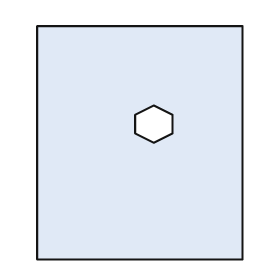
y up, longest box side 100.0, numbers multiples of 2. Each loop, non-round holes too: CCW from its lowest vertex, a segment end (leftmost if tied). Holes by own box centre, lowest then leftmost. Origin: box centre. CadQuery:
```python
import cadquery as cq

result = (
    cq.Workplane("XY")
    .moveTo(-44.0, -50.0)
    .lineTo(44.0, -50.0)
    .lineTo(44.0, 50.0)
    .lineTo(-44.0, 50.0)
    .close()
    .moveTo(6.0, 0.0)
    .lineTo(14.0, 4.0)
    .lineTo(14.0, 12.0)
    .lineTo(6.0, 16.0)
    .lineTo(-2.0, 12.0)
    .lineTo(-2.0, 4.0)
    .close()
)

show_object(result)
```